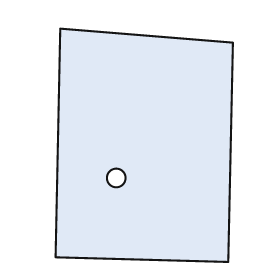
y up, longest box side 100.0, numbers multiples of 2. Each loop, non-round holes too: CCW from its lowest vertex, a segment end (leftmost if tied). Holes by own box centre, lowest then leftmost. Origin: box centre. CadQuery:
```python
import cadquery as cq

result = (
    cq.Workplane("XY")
    .moveTo(36.0, -50.0)
    .lineTo(38.0, 44.0)
    .lineTo(-36.0, 50.0)
    .lineTo(-38.0, -48.0)
    .close()
    .moveTo(-12.0, -14.0)
    .circle(4.0)
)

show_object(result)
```